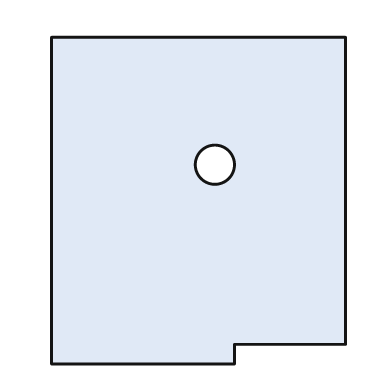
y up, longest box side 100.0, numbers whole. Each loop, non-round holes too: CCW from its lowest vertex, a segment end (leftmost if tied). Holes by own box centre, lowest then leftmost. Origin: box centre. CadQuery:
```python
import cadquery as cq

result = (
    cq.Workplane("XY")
    .moveTo(-45.0, -50.0)
    .lineTo(11.0, -50.0)
    .lineTo(11.0, -44.0)
    .lineTo(45.0, -44.0)
    .lineTo(45.0, 50.0)
    .lineTo(-45.0, 50.0)
    .close()
    .moveTo(5.0, 11.0)
    .circle(6.0)
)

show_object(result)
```